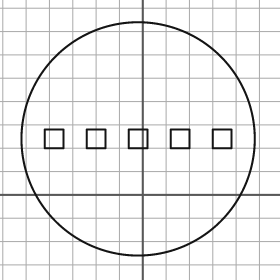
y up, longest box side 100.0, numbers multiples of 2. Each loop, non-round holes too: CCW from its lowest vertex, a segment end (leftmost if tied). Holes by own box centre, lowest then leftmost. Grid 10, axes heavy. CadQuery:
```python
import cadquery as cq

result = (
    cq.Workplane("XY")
    .moveTo(-2.0, 24.0)
    .circle(50.0)
    .moveTo(-42.0, 20.0)
    .lineTo(-34.0, 20.0)
    .lineTo(-34.0, 28.0)
    .lineTo(-42.0, 28.0)
    .close()
    .moveTo(-24.0, 20.0)
    .lineTo(-16.0, 20.0)
    .lineTo(-16.0, 28.0)
    .lineTo(-24.0, 28.0)
    .close()
    .moveTo(-6.0, 20.0)
    .lineTo(2.0, 20.0)
    .lineTo(2.0, 28.0)
    .lineTo(-6.0, 28.0)
    .close()
    .moveTo(12.0, 20.0)
    .lineTo(20.0, 20.0)
    .lineTo(20.0, 28.0)
    .lineTo(12.0, 28.0)
    .close()
    .moveTo(30.0, 20.0)
    .lineTo(38.0, 20.0)
    .lineTo(38.0, 28.0)
    .lineTo(30.0, 28.0)
    .close()
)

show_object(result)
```